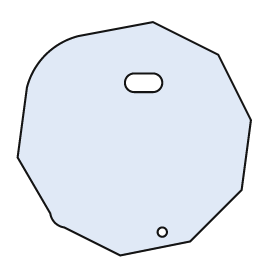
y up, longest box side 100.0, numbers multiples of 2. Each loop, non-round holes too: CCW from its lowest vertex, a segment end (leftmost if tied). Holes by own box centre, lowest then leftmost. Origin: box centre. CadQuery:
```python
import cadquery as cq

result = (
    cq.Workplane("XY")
    .moveTo(-6.0, -50.0)
    .lineTo(24.0, -44.0)
    .lineTo(46.0, -22.0)
    .lineTo(50.0, 8.0)
    .lineTo(36.0, 36.0)
    .lineTo(8.0, 50.0)
    .lineTo(-24.0, 44.0)
    .threePointArc((-38.0, 36.0), (-46.0, 22.0))
    .lineTo(-50.0, -8.0)
    .lineTo(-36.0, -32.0)
    .threePointArc((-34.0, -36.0), (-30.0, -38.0))
    .close()
    .moveTo(12.0, -40.0)
    .circle(2.0)
    .moveTo(0.0, 20.0)
    .lineTo(8.0, 20.0)
    .threePointArc((12.0, 24.0), (8.0, 28.0))
    .lineTo(0.0, 28.0)
    .threePointArc((-4.0, 24.0), (0.0, 20.0))
    .close()
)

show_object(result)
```